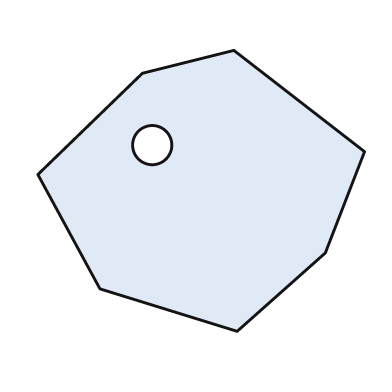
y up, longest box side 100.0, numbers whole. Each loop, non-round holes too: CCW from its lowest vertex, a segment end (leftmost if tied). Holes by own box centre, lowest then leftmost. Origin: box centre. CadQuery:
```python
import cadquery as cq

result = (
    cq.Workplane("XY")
    .moveTo(11.0, -43.0)
    .lineTo(38.0, -19.0)
    .lineTo(50.0, 12.0)
    .lineTo(10.0, 43.0)
    .lineTo(-18.0, 36.0)
    .lineTo(-50.0, 5.0)
    .lineTo(-31.0, -30.0)
    .close()
    .moveTo(-15.0, 14.0)
    .circle(6.0)
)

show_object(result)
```